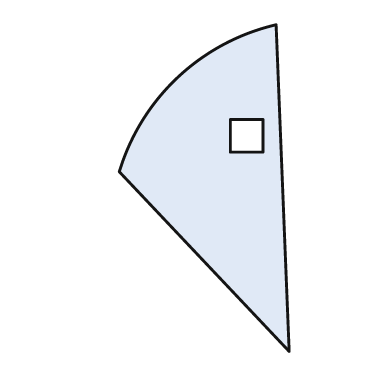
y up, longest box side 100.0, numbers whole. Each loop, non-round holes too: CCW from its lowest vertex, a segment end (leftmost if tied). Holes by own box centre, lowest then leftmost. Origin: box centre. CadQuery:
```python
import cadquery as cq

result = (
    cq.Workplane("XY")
    .moveTo(26.0, -50.0)
    .lineTo(22.0, 50.0)
    .threePointArc((-8.0, 34.0), (-26.0, 5.0))
    .close()
    .moveTo(8.0, 11.0)
    .lineTo(18.0, 11.0)
    .lineTo(18.0, 21.0)
    .lineTo(8.0, 21.0)
    .close()
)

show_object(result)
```